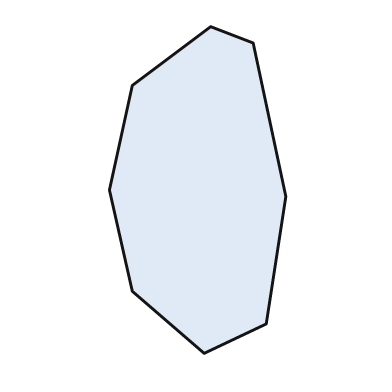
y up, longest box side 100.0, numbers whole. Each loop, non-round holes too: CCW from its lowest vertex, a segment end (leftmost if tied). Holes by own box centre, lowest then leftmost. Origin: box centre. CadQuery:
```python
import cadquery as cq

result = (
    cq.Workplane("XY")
    .moveTo(2.0, -50.0)
    .lineTo(21.0, -41.0)
    .lineTo(27.0, -2.0)
    .lineTo(17.0, 45.0)
    .lineTo(4.0, 50.0)
    .lineTo(-20.0, 32.0)
    .lineTo(-27.0, 0.0)
    .lineTo(-20.0, -31.0)
    .close()
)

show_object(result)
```